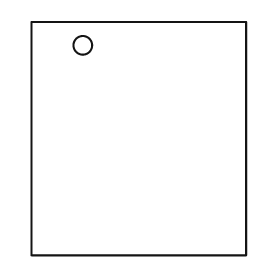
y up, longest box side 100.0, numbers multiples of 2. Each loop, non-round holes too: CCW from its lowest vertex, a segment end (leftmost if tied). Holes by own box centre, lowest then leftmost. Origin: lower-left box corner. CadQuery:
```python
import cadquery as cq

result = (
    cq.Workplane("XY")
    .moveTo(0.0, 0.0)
    .lineTo(92.0, 0.0)
    .lineTo(92.0, 100.0)
    .lineTo(0.0, 100.0)
    .close()
    .moveTo(22.0, 90.0)
    .circle(4.0)
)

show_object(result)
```